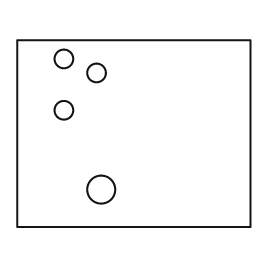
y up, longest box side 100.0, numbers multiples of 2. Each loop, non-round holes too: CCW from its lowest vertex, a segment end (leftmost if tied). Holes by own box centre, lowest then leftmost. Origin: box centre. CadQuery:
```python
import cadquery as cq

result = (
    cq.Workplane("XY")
    .moveTo(-50.0, -40.0)
    .lineTo(50.0, -40.0)
    .lineTo(50.0, 40.0)
    .lineTo(-50.0, 40.0)
    .close()
    .moveTo(-14.0, -24.0)
    .circle(6.0)
    .moveTo(-30.0, 10.0)
    .circle(4.0)
    .moveTo(-16.0, 26.0)
    .circle(4.0)
    .moveTo(-30.0, 32.0)
    .circle(4.0)
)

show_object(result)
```